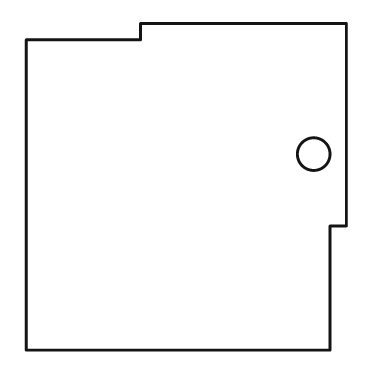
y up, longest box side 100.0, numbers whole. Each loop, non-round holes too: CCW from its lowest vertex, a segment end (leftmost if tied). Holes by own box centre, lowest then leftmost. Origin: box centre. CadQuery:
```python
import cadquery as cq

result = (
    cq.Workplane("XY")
    .moveTo(-49.0, -50.0)
    .lineTo(44.0, -50.0)
    .lineTo(44.0, -12.0)
    .lineTo(49.0, -12.0)
    .lineTo(49.0, 50.0)
    .lineTo(-14.0, 50.0)
    .lineTo(-14.0, 45.0)
    .lineTo(-49.0, 45.0)
    .close()
    .moveTo(39.0, 10.0)
    .circle(5.0)
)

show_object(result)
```